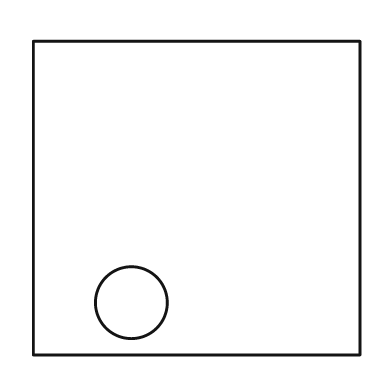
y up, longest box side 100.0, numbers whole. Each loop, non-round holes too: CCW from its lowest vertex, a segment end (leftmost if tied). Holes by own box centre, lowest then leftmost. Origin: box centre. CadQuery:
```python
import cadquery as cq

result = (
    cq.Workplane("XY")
    .moveTo(-50.0, -48.0)
    .lineTo(50.0, -48.0)
    .lineTo(50.0, 48.0)
    .lineTo(-50.0, 48.0)
    .close()
    .moveTo(-20.0, -32.0)
    .circle(11.0)
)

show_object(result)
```